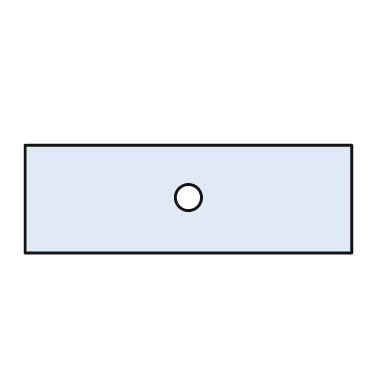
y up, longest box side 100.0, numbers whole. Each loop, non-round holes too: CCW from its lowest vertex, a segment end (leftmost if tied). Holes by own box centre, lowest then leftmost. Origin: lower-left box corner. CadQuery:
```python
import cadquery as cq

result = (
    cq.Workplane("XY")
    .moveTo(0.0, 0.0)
    .lineTo(100.0, 0.0)
    .lineTo(100.0, 33.0)
    .lineTo(0.0, 33.0)
    .close()
    .moveTo(50.0, 17.0)
    .circle(4.0)
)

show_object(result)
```